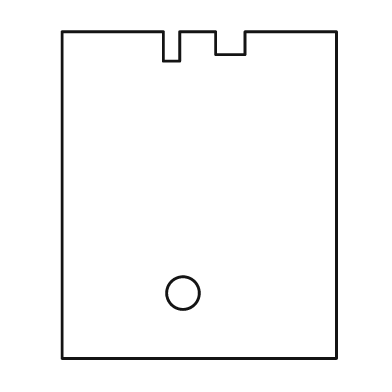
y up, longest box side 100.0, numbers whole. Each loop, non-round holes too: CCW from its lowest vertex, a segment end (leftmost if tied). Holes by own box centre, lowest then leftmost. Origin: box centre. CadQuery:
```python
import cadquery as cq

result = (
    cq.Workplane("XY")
    .moveTo(-42.0, -50.0)
    .lineTo(42.0, -50.0)
    .lineTo(42.0, 50.0)
    .lineTo(14.0, 50.0)
    .lineTo(14.0, 43.0)
    .lineTo(5.0, 43.0)
    .lineTo(5.0, 50.0)
    .lineTo(-6.0, 50.0)
    .lineTo(-6.0, 41.0)
    .lineTo(-11.0, 41.0)
    .lineTo(-11.0, 50.0)
    .lineTo(-42.0, 50.0)
    .close()
    .moveTo(-5.0, -30.0)
    .circle(5.0)
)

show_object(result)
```